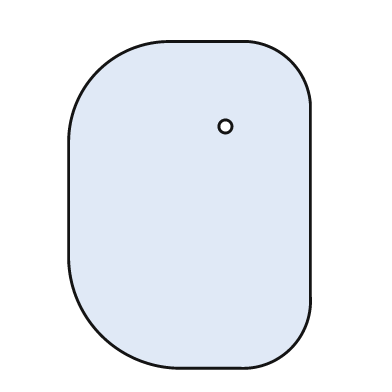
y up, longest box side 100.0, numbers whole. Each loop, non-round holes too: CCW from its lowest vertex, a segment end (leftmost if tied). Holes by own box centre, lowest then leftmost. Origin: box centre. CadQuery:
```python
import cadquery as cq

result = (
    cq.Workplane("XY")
    .moveTo(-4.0, -50.0)
    .lineTo(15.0, -50.0)
    .threePointArc((31.0, -44.0), (37.0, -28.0))
    .lineTo(37.0, 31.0)
    .threePointArc((31.0, 44.0), (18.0, 50.0))
    .lineTo(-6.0, 50.0)
    .threePointArc((-28.0, 41.0), (-37.0, 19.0))
    .lineTo(-37.0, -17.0)
    .threePointArc((-27.0, -40.0), (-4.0, -50.0))
    .close()
    .moveTo(11.0, 24.0)
    .circle(2.0)
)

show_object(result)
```